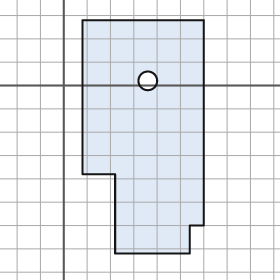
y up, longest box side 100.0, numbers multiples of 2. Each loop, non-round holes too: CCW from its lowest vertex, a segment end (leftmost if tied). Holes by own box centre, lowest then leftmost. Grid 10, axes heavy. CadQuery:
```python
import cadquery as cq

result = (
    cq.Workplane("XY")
    .moveTo(22.0, -72.0)
    .lineTo(54.0, -72.0)
    .lineTo(54.0, -60.0)
    .lineTo(60.0, -60.0)
    .lineTo(60.0, 28.0)
    .lineTo(8.0, 28.0)
    .lineTo(8.0, -38.0)
    .lineTo(22.0, -38.0)
    .close()
    .moveTo(36.0, 2.0)
    .circle(4.0)
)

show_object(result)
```